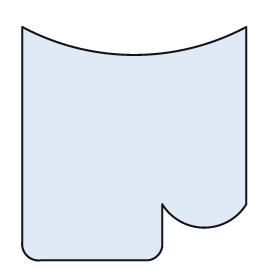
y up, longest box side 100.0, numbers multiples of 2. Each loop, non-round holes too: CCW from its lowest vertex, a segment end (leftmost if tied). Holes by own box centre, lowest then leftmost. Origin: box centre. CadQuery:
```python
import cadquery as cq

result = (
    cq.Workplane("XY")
    .moveTo(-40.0, -50.0)
    .lineTo(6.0, -50.0)
    .threePointArc((10.0, -48.0), (12.0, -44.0))
    .lineTo(12.0, -26.0)
    .threePointArc((30.0, -36.0), (48.0, -26.0))
    .lineTo(48.0, 50.0)
    .threePointArc((0.0, 38.0), (-48.0, 50.0))
    .lineTo(-48.0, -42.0)
    .threePointArc((-46.0, -48.0), (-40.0, -50.0))
    .close()
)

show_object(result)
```